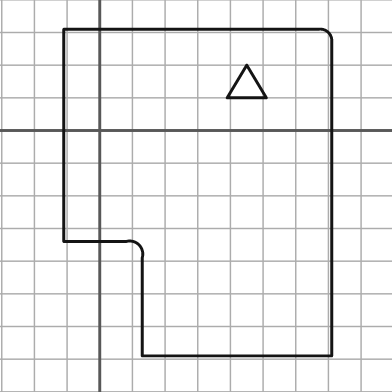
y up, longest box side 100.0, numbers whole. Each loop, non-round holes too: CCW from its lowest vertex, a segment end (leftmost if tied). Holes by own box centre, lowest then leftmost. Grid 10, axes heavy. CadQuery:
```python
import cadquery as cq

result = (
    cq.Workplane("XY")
    .moveTo(13.0, -69.0)
    .lineTo(71.0, -69.0)
    .lineTo(71.0, 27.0)
    .threePointArc((70.0, 30.0), (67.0, 31.0))
    .lineTo(-11.0, 31.0)
    .lineTo(-11.0, -34.0)
    .lineTo(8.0, -34.0)
    .threePointArc((12.0, -35.0), (13.0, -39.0))
    .close()
    .moveTo(39.0, 10.0)
    .lineTo(51.0, 10.0)
    .lineTo(45.0, 20.0)
    .close()
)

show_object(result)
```